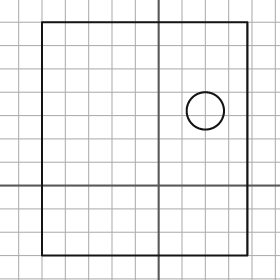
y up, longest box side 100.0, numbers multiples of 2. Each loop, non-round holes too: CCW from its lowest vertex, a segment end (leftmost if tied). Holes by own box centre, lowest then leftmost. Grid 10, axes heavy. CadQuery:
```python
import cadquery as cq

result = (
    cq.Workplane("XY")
    .moveTo(-50.0, -30.0)
    .lineTo(38.0, -30.0)
    .lineTo(38.0, 70.0)
    .lineTo(-50.0, 70.0)
    .close()
    .moveTo(20.0, 32.0)
    .circle(8.0)
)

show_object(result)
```